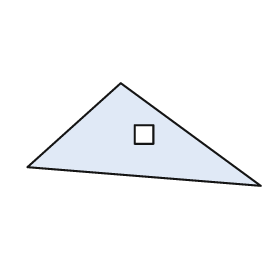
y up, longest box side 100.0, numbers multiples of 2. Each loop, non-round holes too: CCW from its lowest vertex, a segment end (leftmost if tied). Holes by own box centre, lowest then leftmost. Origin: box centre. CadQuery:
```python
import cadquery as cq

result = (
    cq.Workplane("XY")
    .moveTo(50.0, -22.0)
    .lineTo(-10.0, 22.0)
    .lineTo(-50.0, -14.0)
    .close()
    .moveTo(-4.0, -4.0)
    .lineTo(4.0, -4.0)
    .lineTo(4.0, 4.0)
    .lineTo(-4.0, 4.0)
    .close()
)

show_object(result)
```